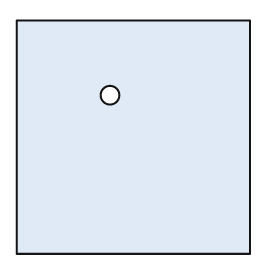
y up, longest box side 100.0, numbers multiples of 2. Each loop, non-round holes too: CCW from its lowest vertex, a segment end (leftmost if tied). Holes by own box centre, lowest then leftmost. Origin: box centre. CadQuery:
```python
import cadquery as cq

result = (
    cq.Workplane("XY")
    .moveTo(-50.0, -50.0)
    .lineTo(50.0, -50.0)
    .lineTo(50.0, 50.0)
    .lineTo(-50.0, 50.0)
    .close()
    .moveTo(-10.0, 18.0)
    .circle(4.0)
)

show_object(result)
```